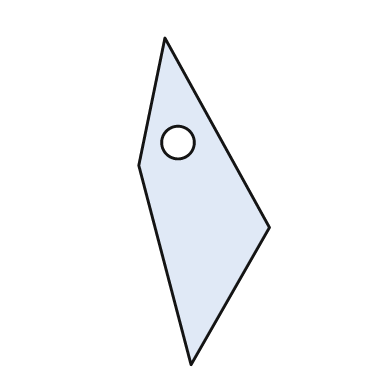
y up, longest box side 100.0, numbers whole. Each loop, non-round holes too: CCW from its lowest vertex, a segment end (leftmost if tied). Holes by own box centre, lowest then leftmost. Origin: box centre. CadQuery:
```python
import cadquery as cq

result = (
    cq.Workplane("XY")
    .moveTo(-4.0, -50.0)
    .lineTo(20.0, -8.0)
    .lineTo(-12.0, 50.0)
    .lineTo(-20.0, 11.0)
    .close()
    .moveTo(-8.0, 18.0)
    .circle(5.0)
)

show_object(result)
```